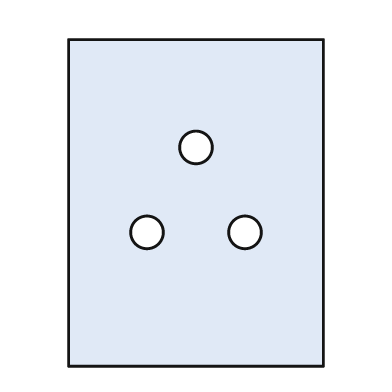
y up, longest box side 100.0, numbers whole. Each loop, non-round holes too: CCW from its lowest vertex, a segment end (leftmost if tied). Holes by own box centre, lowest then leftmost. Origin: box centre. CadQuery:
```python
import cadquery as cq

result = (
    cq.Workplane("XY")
    .moveTo(-39.0, -50.0)
    .lineTo(39.0, -50.0)
    .lineTo(39.0, 50.0)
    .lineTo(-39.0, 50.0)
    .close()
    .moveTo(-15.0, -9.0)
    .circle(5.0)
    .moveTo(15.0, -9.0)
    .circle(5.0)
    .moveTo(0.0, 17.0)
    .circle(5.0)
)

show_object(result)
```